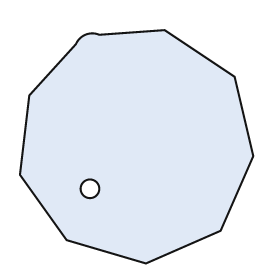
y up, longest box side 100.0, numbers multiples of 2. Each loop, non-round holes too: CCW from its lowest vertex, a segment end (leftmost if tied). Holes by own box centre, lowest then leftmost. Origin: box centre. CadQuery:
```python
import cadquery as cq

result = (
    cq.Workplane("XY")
    .moveTo(4.0, -50.0)
    .lineTo(36.0, -36.0)
    .lineTo(50.0, -4.0)
    .lineTo(42.0, 30.0)
    .lineTo(12.0, 50.0)
    .lineTo(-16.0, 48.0)
    .threePointArc((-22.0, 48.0), (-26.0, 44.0))
    .lineTo(-46.0, 22.0)
    .lineTo(-50.0, -12.0)
    .lineTo(-30.0, -40.0)
    .close()
    .moveTo(-20.0, -18.0)
    .circle(4.0)
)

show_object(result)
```